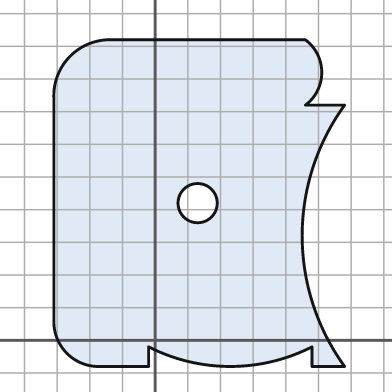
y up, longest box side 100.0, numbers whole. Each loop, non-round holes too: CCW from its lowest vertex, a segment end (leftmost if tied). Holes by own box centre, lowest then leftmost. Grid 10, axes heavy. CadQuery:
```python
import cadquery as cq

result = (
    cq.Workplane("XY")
    .moveTo(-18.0, -8.0)
    .lineTo(-2.0, -8.0)
    .lineTo(-2.0, -2.0)
    .threePointArc((23.0, -8.0), (48.0, -2.0))
    .lineTo(48.0, -8.0)
    .lineTo(58.0, -8.0)
    .threePointArc((45.0, 32.0), (58.0, 72.0))
    .lineTo(46.0, 72.0)
    .threePointArc((51.0, 82.0), (46.0, 92.0))
    .lineTo(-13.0, 92.0)
    .threePointArc((-26.0, 87.0), (-31.0, 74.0))
    .lineTo(-31.0, 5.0)
    .threePointArc((-27.0, -4.0), (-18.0, -8.0))
    .close()
    .moveTo(13.0, 42.0)
    .circle(6.0)
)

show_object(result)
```